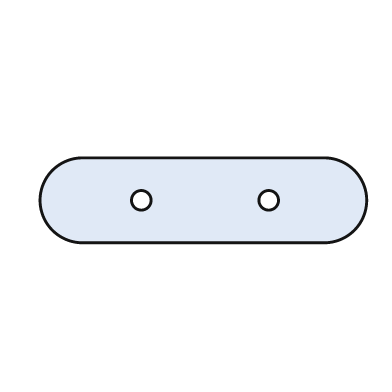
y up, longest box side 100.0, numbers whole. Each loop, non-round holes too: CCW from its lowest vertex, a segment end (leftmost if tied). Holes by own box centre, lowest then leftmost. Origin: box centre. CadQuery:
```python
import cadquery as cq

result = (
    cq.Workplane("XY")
    .moveTo(-37.0, -13.0)
    .lineTo(37.0, -13.0)
    .threePointArc((50.0, 0.0), (37.0, 13.0))
    .lineTo(-37.0, 13.0)
    .threePointArc((-50.0, 0.0), (-37.0, -13.0))
    .close()
    .moveTo(-19.0, 0.0)
    .circle(3.0)
    .moveTo(20.0, 0.0)
    .circle(3.0)
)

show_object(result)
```